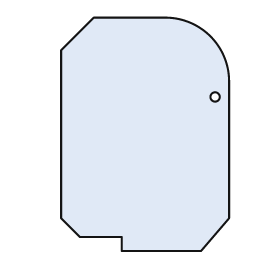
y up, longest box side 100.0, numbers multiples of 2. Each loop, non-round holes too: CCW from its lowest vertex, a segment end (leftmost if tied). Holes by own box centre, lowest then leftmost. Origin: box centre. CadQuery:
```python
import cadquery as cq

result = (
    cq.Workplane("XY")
    .moveTo(-10.0, -50.0)
    .lineTo(24.0, -50.0)
    .lineTo(36.0, -36.0)
    .lineTo(36.0, 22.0)
    .threePointArc((28.0, 42.0), (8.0, 50.0))
    .lineTo(-22.0, 50.0)
    .lineTo(-36.0, 36.0)
    .lineTo(-36.0, -36.0)
    .lineTo(-28.0, -44.0)
    .lineTo(-10.0, -44.0)
    .close()
    .moveTo(30.0, 16.0)
    .circle(2.0)
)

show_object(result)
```